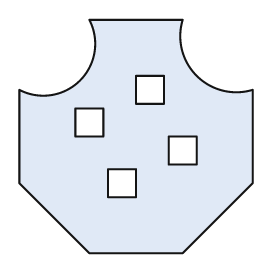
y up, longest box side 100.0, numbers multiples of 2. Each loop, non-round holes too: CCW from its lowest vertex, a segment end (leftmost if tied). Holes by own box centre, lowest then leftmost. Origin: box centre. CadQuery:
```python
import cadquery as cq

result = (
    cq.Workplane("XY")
    .moveTo(-20.0, -50.0)
    .lineTo(20.0, -50.0)
    .lineTo(50.0, -20.0)
    .lineTo(50.0, 20.0)
    .threePointArc((26.0, 26.0), (20.0, 50.0))
    .lineTo(-20.0, 50.0)
    .threePointArc((-24.0, 24.0), (-50.0, 20.0))
    .lineTo(-50.0, -20.0)
    .close()
    .moveTo(-12.0, -26.0)
    .lineTo(0.0, -26.0)
    .lineTo(0.0, -14.0)
    .lineTo(-12.0, -14.0)
    .close()
    .moveTo(14.0, -12.0)
    .lineTo(26.0, -12.0)
    .lineTo(26.0, 0.0)
    .lineTo(14.0, 0.0)
    .close()
    .moveTo(-26.0, 0.0)
    .lineTo(-14.0, 0.0)
    .lineTo(-14.0, 12.0)
    .lineTo(-26.0, 12.0)
    .close()
    .moveTo(0.0, 14.0)
    .lineTo(12.0, 14.0)
    .lineTo(12.0, 26.0)
    .lineTo(0.0, 26.0)
    .close()
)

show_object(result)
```